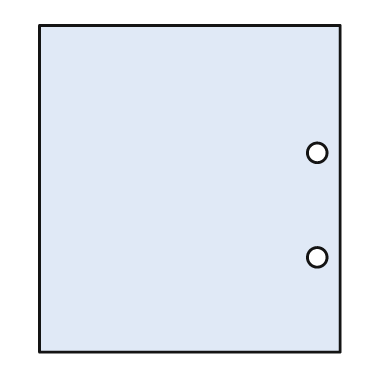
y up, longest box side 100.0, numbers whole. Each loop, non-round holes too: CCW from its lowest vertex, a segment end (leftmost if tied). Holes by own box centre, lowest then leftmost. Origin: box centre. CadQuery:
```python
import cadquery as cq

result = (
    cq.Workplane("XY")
    .moveTo(-46.0, -50.0)
    .lineTo(46.0, -50.0)
    .lineTo(46.0, 50.0)
    .lineTo(-46.0, 50.0)
    .close()
    .moveTo(39.0, -21.0)
    .circle(3.0)
    .moveTo(39.0, 11.0)
    .circle(3.0)
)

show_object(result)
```